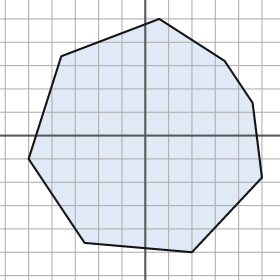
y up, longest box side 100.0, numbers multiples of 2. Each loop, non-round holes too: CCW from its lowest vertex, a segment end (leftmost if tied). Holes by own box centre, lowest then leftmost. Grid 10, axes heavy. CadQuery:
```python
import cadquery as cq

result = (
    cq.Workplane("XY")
    .moveTo(20.0, -50.0)
    .lineTo(50.0, -18.0)
    .lineTo(46.0, 14.0)
    .lineTo(34.0, 32.0)
    .lineTo(6.0, 50.0)
    .lineTo(-36.0, 34.0)
    .lineTo(-50.0, -10.0)
    .lineTo(-26.0, -46.0)
    .close()
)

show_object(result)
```